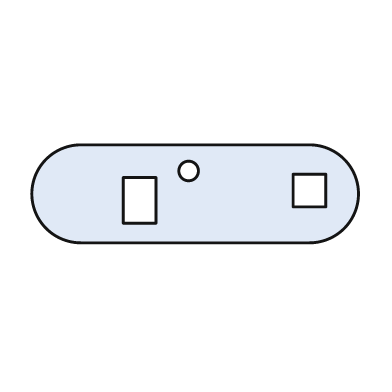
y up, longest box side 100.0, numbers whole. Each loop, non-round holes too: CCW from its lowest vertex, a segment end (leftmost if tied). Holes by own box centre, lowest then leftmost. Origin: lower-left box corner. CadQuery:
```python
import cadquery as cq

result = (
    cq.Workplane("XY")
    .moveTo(15.0, 0.0)
    .lineTo(85.0, 0.0)
    .threePointArc((100.0, 15.0), (85.0, 30.0))
    .lineTo(15.0, 30.0)
    .threePointArc((0.0, 15.0), (15.0, 0.0))
    .close()
    .moveTo(28.0, 6.0)
    .lineTo(38.0, 6.0)
    .lineTo(38.0, 20.0)
    .lineTo(28.0, 20.0)
    .close()
    .moveTo(80.0, 11.0)
    .lineTo(90.0, 11.0)
    .lineTo(90.0, 21.0)
    .lineTo(80.0, 21.0)
    .close()
    .moveTo(48.0, 22.0)
    .circle(3.0)
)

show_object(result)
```